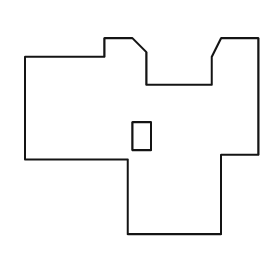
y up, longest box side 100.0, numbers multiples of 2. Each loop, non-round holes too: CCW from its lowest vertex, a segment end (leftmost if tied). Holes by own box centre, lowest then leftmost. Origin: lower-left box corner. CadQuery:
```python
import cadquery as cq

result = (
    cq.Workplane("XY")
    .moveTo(44.0, 0.0)
    .lineTo(84.0, 0.0)
    .lineTo(84.0, 34.0)
    .lineTo(100.0, 34.0)
    .lineTo(100.0, 84.0)
    .lineTo(84.0, 84.0)
    .lineTo(80.0, 76.0)
    .lineTo(80.0, 64.0)
    .lineTo(52.0, 64.0)
    .lineTo(52.0, 78.0)
    .lineTo(46.0, 84.0)
    .lineTo(34.0, 84.0)
    .lineTo(34.0, 76.0)
    .lineTo(0.0, 76.0)
    .lineTo(0.0, 32.0)
    .lineTo(44.0, 32.0)
    .close()
    .moveTo(46.0, 36.0)
    .lineTo(54.0, 36.0)
    .lineTo(54.0, 48.0)
    .lineTo(46.0, 48.0)
    .close()
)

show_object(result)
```